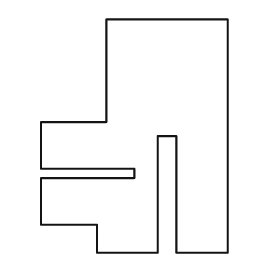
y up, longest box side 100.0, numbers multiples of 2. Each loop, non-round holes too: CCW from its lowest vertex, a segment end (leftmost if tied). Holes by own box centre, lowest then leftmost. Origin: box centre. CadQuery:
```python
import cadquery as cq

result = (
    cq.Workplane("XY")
    .moveTo(-16.0, -50.0)
    .lineTo(10.0, -50.0)
    .lineTo(10.0, 0.0)
    .lineTo(18.0, 0.0)
    .lineTo(18.0, -50.0)
    .lineTo(40.0, -50.0)
    .lineTo(40.0, 50.0)
    .lineTo(-12.0, 50.0)
    .lineTo(-12.0, 6.0)
    .lineTo(-40.0, 6.0)
    .lineTo(-40.0, -14.0)
    .lineTo(0.0, -14.0)
    .lineTo(0.0, -18.0)
    .lineTo(-40.0, -18.0)
    .lineTo(-40.0, -38.0)
    .lineTo(-16.0, -38.0)
    .close()
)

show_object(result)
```